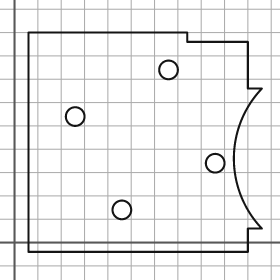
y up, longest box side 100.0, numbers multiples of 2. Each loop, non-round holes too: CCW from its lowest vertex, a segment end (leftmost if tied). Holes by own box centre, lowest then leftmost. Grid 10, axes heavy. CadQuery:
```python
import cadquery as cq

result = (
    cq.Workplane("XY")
    .moveTo(6.0, -4.0)
    .lineTo(100.0, -4.0)
    .lineTo(100.0, 6.0)
    .lineTo(106.0, 6.0)
    .threePointArc((94.0, 36.0), (106.0, 66.0))
    .lineTo(100.0, 66.0)
    .lineTo(100.0, 86.0)
    .lineTo(74.0, 86.0)
    .lineTo(74.0, 90.0)
    .lineTo(6.0, 90.0)
    .close()
    .moveTo(46.0, 14.0)
    .circle(4.0)
    .moveTo(86.0, 34.0)
    .circle(4.0)
    .moveTo(26.0, 54.0)
    .circle(4.0)
    .moveTo(66.0, 74.0)
    .circle(4.0)
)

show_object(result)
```